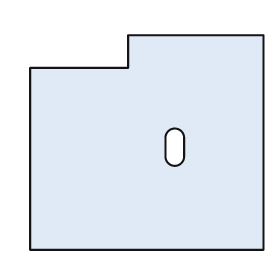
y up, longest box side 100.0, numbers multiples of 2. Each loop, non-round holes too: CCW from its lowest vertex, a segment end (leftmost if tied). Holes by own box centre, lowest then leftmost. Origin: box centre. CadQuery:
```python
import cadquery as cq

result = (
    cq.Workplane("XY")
    .moveTo(-50.0, -46.0)
    .lineTo(50.0, -46.0)
    .lineTo(50.0, 46.0)
    .lineTo(-8.0, 46.0)
    .lineTo(-8.0, 32.0)
    .lineTo(-50.0, 32.0)
    .close()
    .moveTo(8.0, -6.0)
    .threePointArc((12.0, -10.0), (16.0, -6.0))
    .lineTo(16.0, 2.0)
    .threePointArc((12.0, 6.0), (8.0, 2.0))
    .close()
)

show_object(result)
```